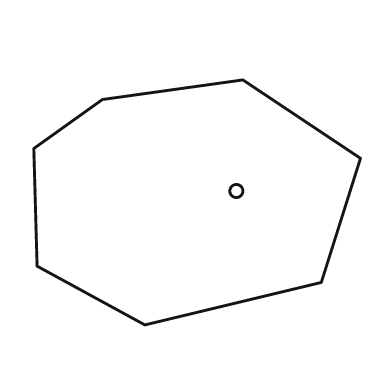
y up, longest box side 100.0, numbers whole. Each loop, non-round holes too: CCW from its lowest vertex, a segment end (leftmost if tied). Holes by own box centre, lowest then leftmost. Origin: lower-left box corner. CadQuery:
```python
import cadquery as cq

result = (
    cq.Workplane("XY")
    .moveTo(34.0, 0.0)
    .lineTo(88.0, 13.0)
    .lineTo(100.0, 51.0)
    .lineTo(64.0, 75.0)
    .lineTo(21.0, 69.0)
    .lineTo(0.0, 54.0)
    .lineTo(1.0, 18.0)
    .close()
    .moveTo(62.0, 41.0)
    .circle(2.0)
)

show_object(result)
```